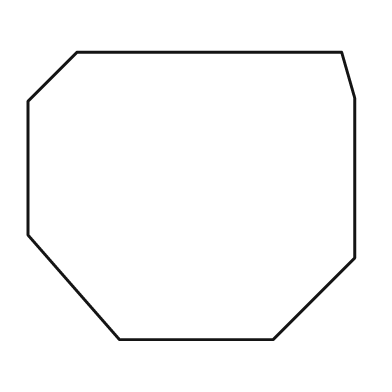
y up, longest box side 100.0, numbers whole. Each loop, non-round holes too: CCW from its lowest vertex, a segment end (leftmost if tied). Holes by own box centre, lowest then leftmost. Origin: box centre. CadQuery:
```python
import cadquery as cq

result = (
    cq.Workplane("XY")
    .moveTo(-22.0, -44.0)
    .lineTo(25.0, -44.0)
    .lineTo(50.0, -19.0)
    .lineTo(50.0, 30.0)
    .lineTo(46.0, 44.0)
    .lineTo(-35.0, 44.0)
    .lineTo(-50.0, 29.0)
    .lineTo(-50.0, -12.0)
    .close()
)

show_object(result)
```